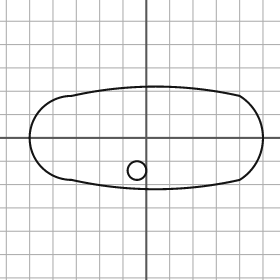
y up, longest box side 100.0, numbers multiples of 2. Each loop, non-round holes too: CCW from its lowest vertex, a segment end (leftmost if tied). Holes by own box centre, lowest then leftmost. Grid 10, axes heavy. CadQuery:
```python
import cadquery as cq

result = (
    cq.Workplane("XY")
    .moveTo(-32.0, -18.0)
    .threePointArc((4.0, -22.0), (40.0, -18.0))
    .threePointArc((50.0, 0.0), (40.0, 18.0))
    .threePointArc((4.0, 22.0), (-32.0, 18.0))
    .threePointArc((-50.0, 0.0), (-32.0, -18.0))
    .close()
    .moveTo(-4.0, -14.0)
    .circle(4.0)
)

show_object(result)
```